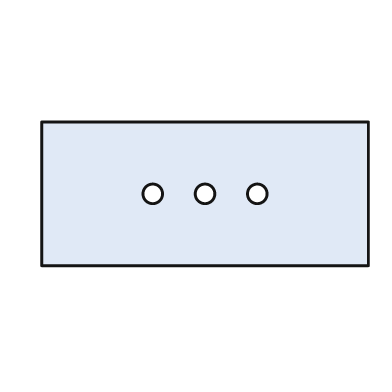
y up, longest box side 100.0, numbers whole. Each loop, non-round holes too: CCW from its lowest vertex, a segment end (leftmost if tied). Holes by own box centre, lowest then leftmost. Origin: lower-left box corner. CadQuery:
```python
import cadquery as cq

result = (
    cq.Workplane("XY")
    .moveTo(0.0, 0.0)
    .lineTo(100.0, 0.0)
    .lineTo(100.0, 44.0)
    .lineTo(0.0, 44.0)
    .close()
    .moveTo(34.0, 22.0)
    .circle(3.0)
    .moveTo(50.0, 22.0)
    .circle(3.0)
    .moveTo(66.0, 22.0)
    .circle(3.0)
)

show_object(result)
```